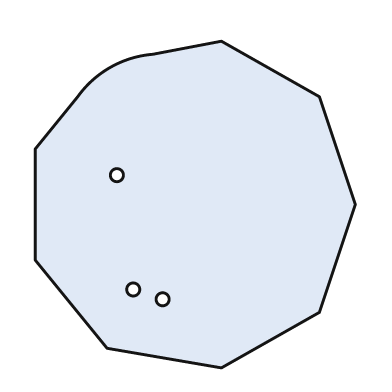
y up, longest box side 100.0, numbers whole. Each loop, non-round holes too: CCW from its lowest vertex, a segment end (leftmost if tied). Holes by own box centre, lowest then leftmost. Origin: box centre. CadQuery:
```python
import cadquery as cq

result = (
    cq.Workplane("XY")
    .moveTo(8.0, -50.0)
    .lineTo(38.0, -33.0)
    .lineTo(49.0, 0.0)
    .lineTo(38.0, 33.0)
    .lineTo(8.0, 50.0)
    .lineTo(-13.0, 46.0)
    .threePointArc((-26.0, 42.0), (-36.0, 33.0))
    .lineTo(-49.0, 17.0)
    .lineTo(-49.0, -17.0)
    .lineTo(-27.0, -44.0)
    .close()
    .moveTo(-10.0, -29.0)
    .circle(2.0)
    .moveTo(-19.0, -26.0)
    .circle(2.0)
    .moveTo(-24.0, 9.0)
    .circle(2.0)
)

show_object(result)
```